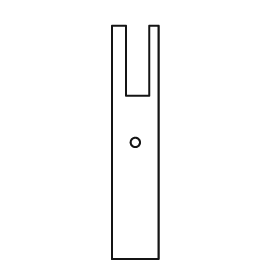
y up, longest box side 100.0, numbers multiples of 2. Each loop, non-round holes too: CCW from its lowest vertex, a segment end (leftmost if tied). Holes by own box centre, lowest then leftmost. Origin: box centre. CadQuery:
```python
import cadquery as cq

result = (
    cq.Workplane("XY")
    .moveTo(-10.0, -50.0)
    .lineTo(10.0, -50.0)
    .lineTo(10.0, 50.0)
    .lineTo(6.0, 50.0)
    .lineTo(6.0, 20.0)
    .lineTo(-4.0, 20.0)
    .lineTo(-4.0, 50.0)
    .lineTo(-10.0, 50.0)
    .close()
    .moveTo(0.0, 0.0)
    .circle(2.0)
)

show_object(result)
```